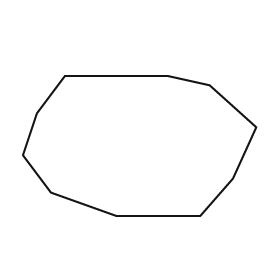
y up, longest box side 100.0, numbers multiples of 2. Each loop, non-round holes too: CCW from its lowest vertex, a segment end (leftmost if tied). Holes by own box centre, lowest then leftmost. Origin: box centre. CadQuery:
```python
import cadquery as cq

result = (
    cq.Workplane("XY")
    .moveTo(-10.0, -30.0)
    .lineTo(26.0, -30.0)
    .lineTo(40.0, -14.0)
    .lineTo(50.0, 8.0)
    .lineTo(30.0, 26.0)
    .lineTo(12.0, 30.0)
    .lineTo(-32.0, 30.0)
    .lineTo(-44.0, 14.0)
    .lineTo(-50.0, -4.0)
    .lineTo(-38.0, -20.0)
    .close()
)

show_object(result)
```